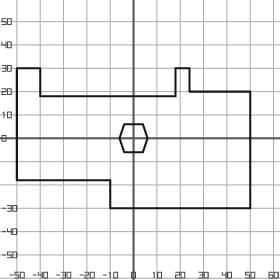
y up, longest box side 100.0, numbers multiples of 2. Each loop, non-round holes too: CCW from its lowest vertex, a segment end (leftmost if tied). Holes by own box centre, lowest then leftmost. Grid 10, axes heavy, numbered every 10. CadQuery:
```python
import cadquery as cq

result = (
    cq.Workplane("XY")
    .moveTo(-10.0, -30.0)
    .lineTo(50.0, -30.0)
    .lineTo(50.0, 20.0)
    .lineTo(24.0, 20.0)
    .lineTo(24.0, 30.0)
    .lineTo(18.0, 30.0)
    .lineTo(18.0, 18.0)
    .lineTo(-40.0, 18.0)
    .lineTo(-40.0, 30.0)
    .lineTo(-50.0, 30.0)
    .lineTo(-50.0, -18.0)
    .lineTo(-10.0, -18.0)
    .close()
    .moveTo(-4.0, -6.0)
    .lineTo(4.0, -6.0)
    .lineTo(6.0, 0.0)
    .lineTo(4.0, 6.0)
    .lineTo(-4.0, 6.0)
    .lineTo(-6.0, 0.0)
    .close()
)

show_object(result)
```